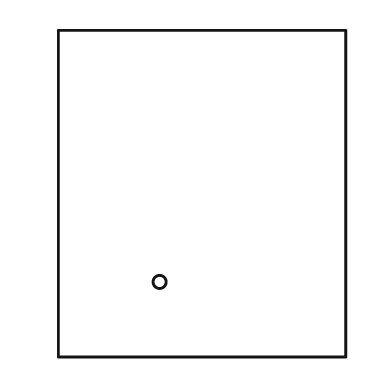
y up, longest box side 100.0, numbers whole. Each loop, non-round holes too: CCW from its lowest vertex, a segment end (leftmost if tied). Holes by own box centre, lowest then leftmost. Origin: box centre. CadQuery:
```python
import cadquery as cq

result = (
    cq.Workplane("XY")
    .moveTo(-44.0, -50.0)
    .lineTo(44.0, -50.0)
    .lineTo(44.0, 50.0)
    .lineTo(-44.0, 50.0)
    .close()
    .moveTo(-13.0, -27.0)
    .circle(2.0)
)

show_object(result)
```